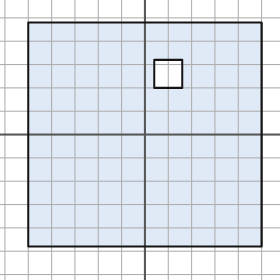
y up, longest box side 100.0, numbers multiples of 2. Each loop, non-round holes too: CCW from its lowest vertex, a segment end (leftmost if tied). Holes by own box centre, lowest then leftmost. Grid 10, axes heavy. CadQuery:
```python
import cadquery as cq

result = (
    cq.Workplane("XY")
    .moveTo(-50.0, -48.0)
    .lineTo(50.0, -48.0)
    .lineTo(50.0, 48.0)
    .lineTo(-50.0, 48.0)
    .close()
    .moveTo(4.0, 20.0)
    .lineTo(16.0, 20.0)
    .lineTo(16.0, 32.0)
    .lineTo(4.0, 32.0)
    .close()
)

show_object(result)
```